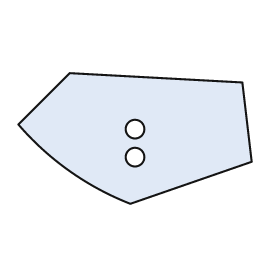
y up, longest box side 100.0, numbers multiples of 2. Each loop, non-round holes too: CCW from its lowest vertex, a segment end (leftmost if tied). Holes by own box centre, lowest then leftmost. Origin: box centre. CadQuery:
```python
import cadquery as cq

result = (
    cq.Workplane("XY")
    .moveTo(-2.0, -28.0)
    .lineTo(50.0, -10.0)
    .lineTo(46.0, 24.0)
    .lineTo(-28.0, 28.0)
    .lineTo(-50.0, 6.0)
    .threePointArc((-28.0, -14.0), (-2.0, -28.0))
    .close()
    .moveTo(0.0, -8.0)
    .circle(4.0)
    .moveTo(0.0, 4.0)
    .circle(4.0)
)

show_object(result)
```